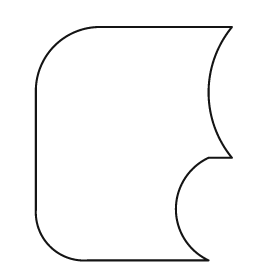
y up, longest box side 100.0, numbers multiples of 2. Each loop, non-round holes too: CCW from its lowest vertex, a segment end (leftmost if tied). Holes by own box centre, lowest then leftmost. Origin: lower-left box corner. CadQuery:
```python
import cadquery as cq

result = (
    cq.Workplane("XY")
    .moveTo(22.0, 0.0)
    .lineTo(74.0, 0.0)
    .threePointArc((60.0, 22.0), (74.0, 44.0))
    .lineTo(84.0, 44.0)
    .threePointArc((74.0, 72.0), (84.0, 100.0))
    .lineTo(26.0, 100.0)
    .threePointArc((8.0, 92.0), (0.0, 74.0))
    .lineTo(0.0, 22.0)
    .threePointArc((6.0, 6.0), (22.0, 0.0))
    .close()
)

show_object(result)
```